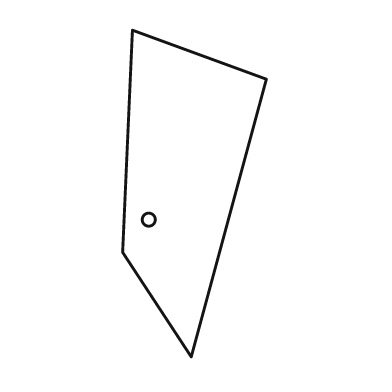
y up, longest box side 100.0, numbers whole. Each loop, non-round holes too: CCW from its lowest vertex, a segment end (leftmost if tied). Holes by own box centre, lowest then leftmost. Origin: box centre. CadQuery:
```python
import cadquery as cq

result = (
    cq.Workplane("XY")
    .moveTo(-1.0, -50.0)
    .lineTo(22.0, 35.0)
    .lineTo(-19.0, 50.0)
    .lineTo(-22.0, -18.0)
    .close()
    .moveTo(-14.0, -8.0)
    .circle(2.0)
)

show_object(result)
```